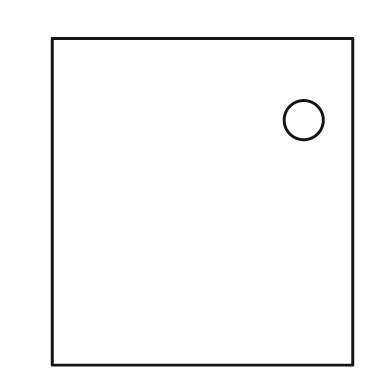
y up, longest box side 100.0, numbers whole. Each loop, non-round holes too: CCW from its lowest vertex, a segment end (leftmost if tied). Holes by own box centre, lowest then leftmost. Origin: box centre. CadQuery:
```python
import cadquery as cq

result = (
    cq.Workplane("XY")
    .moveTo(-46.0, -50.0)
    .lineTo(46.0, -50.0)
    .lineTo(46.0, 50.0)
    .lineTo(-46.0, 50.0)
    .close()
    .moveTo(31.0, 25.0)
    .circle(6.0)
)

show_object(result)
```